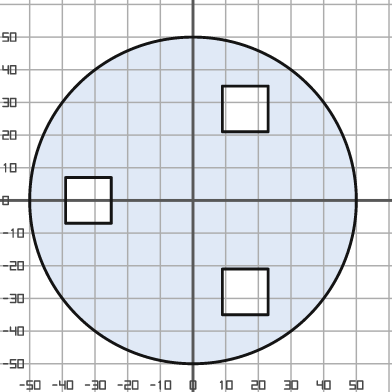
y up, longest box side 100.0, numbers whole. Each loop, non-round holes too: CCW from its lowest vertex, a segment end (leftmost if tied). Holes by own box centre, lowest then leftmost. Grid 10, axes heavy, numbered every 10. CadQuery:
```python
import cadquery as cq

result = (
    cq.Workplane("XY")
    .moveTo(0.0, 0.0)
    .circle(50.0)
    .moveTo(9.0, -35.0)
    .lineTo(23.0, -35.0)
    .lineTo(23.0, -21.0)
    .lineTo(9.0, -21.0)
    .close()
    .moveTo(-39.0, -7.0)
    .lineTo(-25.0, -7.0)
    .lineTo(-25.0, 7.0)
    .lineTo(-39.0, 7.0)
    .close()
    .moveTo(9.0, 21.0)
    .lineTo(23.0, 21.0)
    .lineTo(23.0, 35.0)
    .lineTo(9.0, 35.0)
    .close()
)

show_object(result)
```